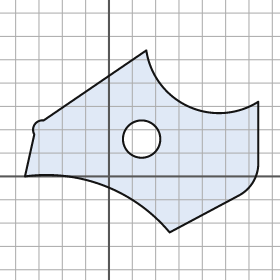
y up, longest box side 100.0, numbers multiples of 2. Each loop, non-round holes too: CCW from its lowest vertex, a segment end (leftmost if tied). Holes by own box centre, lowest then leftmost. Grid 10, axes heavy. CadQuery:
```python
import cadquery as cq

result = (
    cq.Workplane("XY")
    .moveTo(26.0, -24.0)
    .lineTo(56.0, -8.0)
    .threePointArc((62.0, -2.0), (64.0, 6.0))
    .lineTo(64.0, 32.0)
    .threePointArc((34.0, 30.0), (16.0, 54.0))
    .lineTo(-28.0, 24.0)
    .threePointArc((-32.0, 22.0), (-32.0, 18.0))
    .lineTo(-36.0, 0.0)
    .threePointArc((-2.0, -4.0), (26.0, -24.0))
    .close()
    .moveTo(14.0, 16.0)
    .circle(8.0)
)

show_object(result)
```